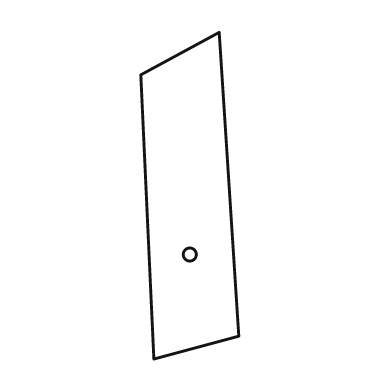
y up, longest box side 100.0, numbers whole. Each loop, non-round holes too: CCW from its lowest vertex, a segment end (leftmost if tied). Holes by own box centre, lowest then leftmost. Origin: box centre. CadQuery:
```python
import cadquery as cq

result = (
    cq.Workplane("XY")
    .moveTo(-11.0, -50.0)
    .lineTo(15.0, -43.0)
    .lineTo(9.0, 50.0)
    .lineTo(-15.0, 37.0)
    .close()
    .moveTo(0.0, -18.0)
    .circle(2.0)
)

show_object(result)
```